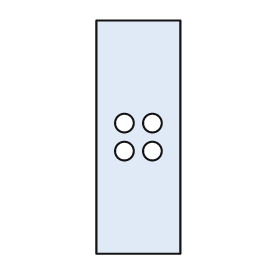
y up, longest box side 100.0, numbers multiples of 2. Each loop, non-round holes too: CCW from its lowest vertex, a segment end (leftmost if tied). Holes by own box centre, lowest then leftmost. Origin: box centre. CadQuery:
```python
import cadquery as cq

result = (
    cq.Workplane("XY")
    .moveTo(-18.0, -50.0)
    .lineTo(18.0, -50.0)
    .lineTo(18.0, 50.0)
    .lineTo(-18.0, 50.0)
    .close()
    .moveTo(-6.0, -6.0)
    .circle(4.0)
    .moveTo(6.0, -6.0)
    .circle(4.0)
    .moveTo(-6.0, 6.0)
    .circle(4.0)
    .moveTo(6.0, 6.0)
    .circle(4.0)
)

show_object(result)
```